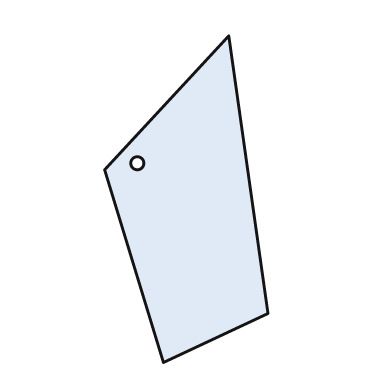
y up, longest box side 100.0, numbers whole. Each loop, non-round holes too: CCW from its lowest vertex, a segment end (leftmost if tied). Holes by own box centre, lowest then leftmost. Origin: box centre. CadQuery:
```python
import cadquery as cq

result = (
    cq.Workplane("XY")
    .moveTo(-7.0, -50.0)
    .lineTo(25.0, -35.0)
    .lineTo(13.0, 50.0)
    .lineTo(-25.0, 9.0)
    .close()
    .moveTo(-15.0, 11.0)
    .circle(2.0)
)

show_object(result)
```